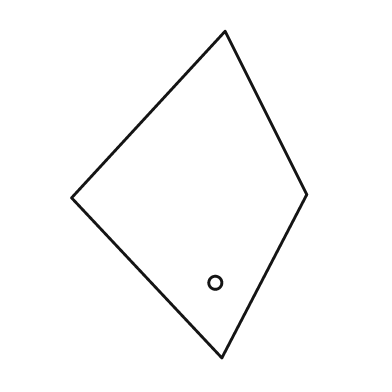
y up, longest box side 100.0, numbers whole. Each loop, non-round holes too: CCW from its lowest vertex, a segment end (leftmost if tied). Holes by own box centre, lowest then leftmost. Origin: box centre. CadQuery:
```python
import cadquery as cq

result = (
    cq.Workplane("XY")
    .moveTo(10.0, -50.0)
    .lineTo(36.0, 0.0)
    .lineTo(11.0, 50.0)
    .lineTo(-36.0, -1.0)
    .close()
    .moveTo(8.0, -27.0)
    .circle(2.0)
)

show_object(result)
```